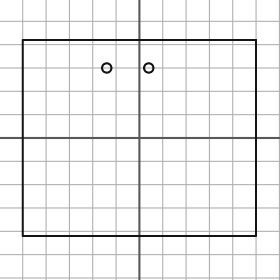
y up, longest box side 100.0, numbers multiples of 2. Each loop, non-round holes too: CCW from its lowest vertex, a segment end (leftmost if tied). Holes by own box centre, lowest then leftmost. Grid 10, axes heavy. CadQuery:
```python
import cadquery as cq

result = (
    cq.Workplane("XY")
    .moveTo(-50.0, -42.0)
    .lineTo(50.0, -42.0)
    .lineTo(50.0, 42.0)
    .lineTo(-50.0, 42.0)
    .close()
    .moveTo(-14.0, 30.0)
    .circle(2.0)
    .moveTo(4.0, 30.0)
    .circle(2.0)
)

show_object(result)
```